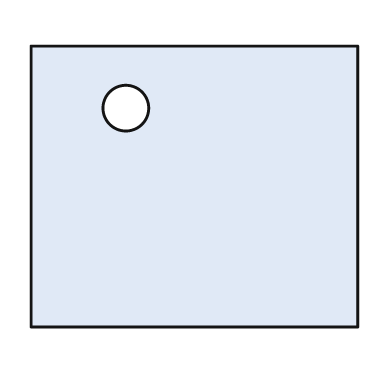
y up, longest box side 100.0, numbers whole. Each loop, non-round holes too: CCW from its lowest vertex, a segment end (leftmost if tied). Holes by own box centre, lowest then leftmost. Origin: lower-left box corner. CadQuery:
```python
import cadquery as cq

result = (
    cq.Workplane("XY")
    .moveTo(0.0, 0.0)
    .lineTo(100.0, 0.0)
    .lineTo(100.0, 86.0)
    .lineTo(0.0, 86.0)
    .close()
    .moveTo(29.0, 67.0)
    .circle(7.0)
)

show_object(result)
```